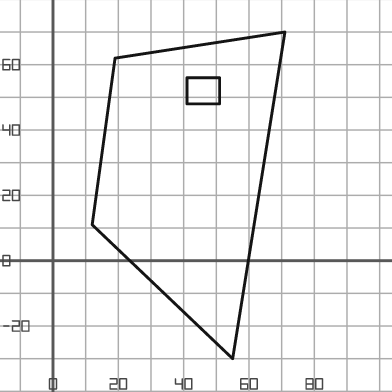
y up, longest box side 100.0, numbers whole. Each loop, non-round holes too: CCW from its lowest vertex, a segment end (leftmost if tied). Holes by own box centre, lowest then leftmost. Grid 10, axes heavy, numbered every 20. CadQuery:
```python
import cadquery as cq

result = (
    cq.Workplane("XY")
    .moveTo(55.0, -30.0)
    .lineTo(71.0, 70.0)
    .lineTo(19.0, 62.0)
    .lineTo(12.0, 11.0)
    .close()
    .moveTo(41.0, 48.0)
    .lineTo(51.0, 48.0)
    .lineTo(51.0, 56.0)
    .lineTo(41.0, 56.0)
    .close()
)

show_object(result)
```